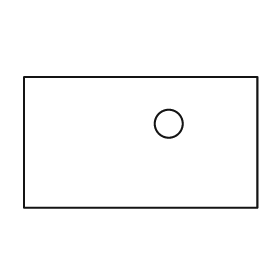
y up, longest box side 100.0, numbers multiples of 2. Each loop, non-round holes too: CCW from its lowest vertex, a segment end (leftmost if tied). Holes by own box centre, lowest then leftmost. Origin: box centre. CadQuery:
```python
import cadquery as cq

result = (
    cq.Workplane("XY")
    .moveTo(-50.0, -28.0)
    .lineTo(50.0, -28.0)
    .lineTo(50.0, 28.0)
    .lineTo(-50.0, 28.0)
    .close()
    .moveTo(12.0, 8.0)
    .circle(6.0)
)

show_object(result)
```